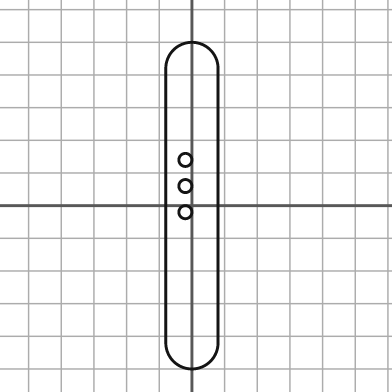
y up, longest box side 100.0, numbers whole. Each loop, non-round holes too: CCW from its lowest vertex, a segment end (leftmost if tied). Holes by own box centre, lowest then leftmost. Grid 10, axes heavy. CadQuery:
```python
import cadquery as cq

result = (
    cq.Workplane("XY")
    .moveTo(-8.0, -42.0)
    .threePointArc((0.0, -50.0), (8.0, -42.0))
    .lineTo(8.0, 42.0)
    .threePointArc((0.0, 50.0), (-8.0, 42.0))
    .close()
    .moveTo(-2.0, -2.0)
    .circle(2.0)
    .moveTo(-2.0, 6.0)
    .circle(2.0)
    .moveTo(-2.0, 14.0)
    .circle(2.0)
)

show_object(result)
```